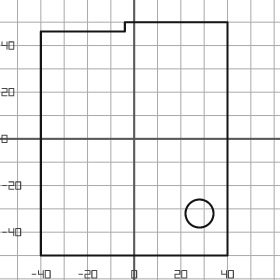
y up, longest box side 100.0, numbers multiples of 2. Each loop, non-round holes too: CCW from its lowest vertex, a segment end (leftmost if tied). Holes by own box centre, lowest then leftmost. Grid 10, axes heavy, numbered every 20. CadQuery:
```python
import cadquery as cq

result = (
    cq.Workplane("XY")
    .moveTo(-40.0, -50.0)
    .lineTo(40.0, -50.0)
    .lineTo(40.0, 50.0)
    .lineTo(-4.0, 50.0)
    .lineTo(-4.0, 46.0)
    .lineTo(-40.0, 46.0)
    .close()
    .moveTo(28.0, -32.0)
    .circle(6.0)
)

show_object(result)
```